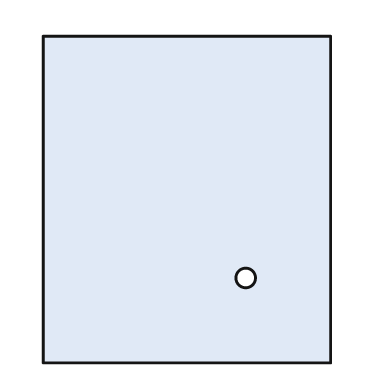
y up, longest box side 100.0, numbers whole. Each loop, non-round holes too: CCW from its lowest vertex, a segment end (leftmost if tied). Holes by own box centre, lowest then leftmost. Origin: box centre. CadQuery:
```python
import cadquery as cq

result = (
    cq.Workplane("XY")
    .moveTo(-44.0, -50.0)
    .lineTo(44.0, -50.0)
    .lineTo(44.0, 50.0)
    .lineTo(-44.0, 50.0)
    .close()
    .moveTo(18.0, -24.0)
    .circle(3.0)
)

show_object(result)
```